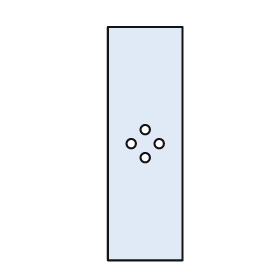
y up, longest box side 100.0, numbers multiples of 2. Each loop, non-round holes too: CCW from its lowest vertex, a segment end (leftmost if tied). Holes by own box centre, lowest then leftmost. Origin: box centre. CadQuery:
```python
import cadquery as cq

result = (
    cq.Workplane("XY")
    .moveTo(-16.0, -50.0)
    .lineTo(16.0, -50.0)
    .lineTo(16.0, 50.0)
    .lineTo(-16.0, 50.0)
    .close()
    .moveTo(0.0, -6.0)
    .circle(2.0)
    .moveTo(-6.0, 0.0)
    .circle(2.0)
    .moveTo(6.0, 0.0)
    .circle(2.0)
    .moveTo(0.0, 6.0)
    .circle(2.0)
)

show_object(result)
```